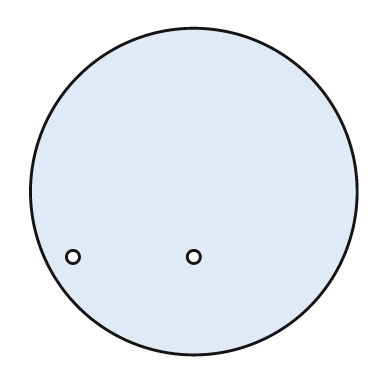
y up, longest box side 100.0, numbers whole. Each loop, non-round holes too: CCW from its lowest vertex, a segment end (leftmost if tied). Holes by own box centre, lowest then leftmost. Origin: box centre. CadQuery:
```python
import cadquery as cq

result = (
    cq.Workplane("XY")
    .moveTo(0.0, 0.0)
    .circle(50.0)
    .moveTo(-37.0, -20.0)
    .circle(2.0)
    .moveTo(0.0, -20.0)
    .circle(2.0)
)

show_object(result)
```